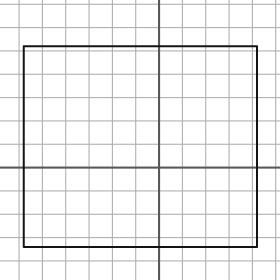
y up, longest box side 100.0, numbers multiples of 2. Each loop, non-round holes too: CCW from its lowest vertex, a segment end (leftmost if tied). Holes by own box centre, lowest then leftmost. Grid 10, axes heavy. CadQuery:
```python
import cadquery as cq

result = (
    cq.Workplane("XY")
    .moveTo(-58.0, -34.0)
    .lineTo(42.0, -34.0)
    .lineTo(42.0, 52.0)
    .lineTo(-58.0, 52.0)
    .close()
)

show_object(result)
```